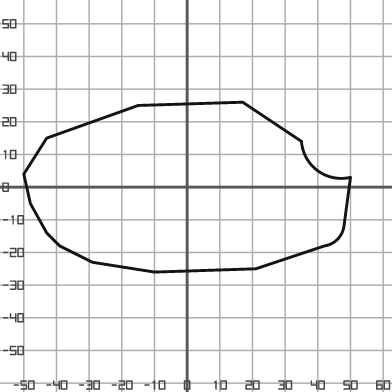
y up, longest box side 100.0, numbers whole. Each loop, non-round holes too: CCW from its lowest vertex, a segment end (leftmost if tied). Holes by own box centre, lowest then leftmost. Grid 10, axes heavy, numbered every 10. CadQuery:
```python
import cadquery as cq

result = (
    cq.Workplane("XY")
    .moveTo(-10.0, -26.0)
    .lineTo(21.0, -25.0)
    .lineTo(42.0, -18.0)
    .threePointArc((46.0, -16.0), (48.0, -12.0))
    .lineTo(50.0, 3.0)
    .threePointArc((40.0, 5.0), (35.0, 14.0))
    .lineTo(17.0, 26.0)
    .lineTo(-15.0, 25.0)
    .lineTo(-43.0, 15.0)
    .lineTo(-50.0, 4.0)
    .lineTo(-48.0, -5.0)
    .lineTo(-43.0, -14.0)
    .lineTo(-39.0, -18.0)
    .lineTo(-29.0, -23.0)
    .close()
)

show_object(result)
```